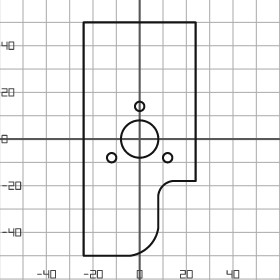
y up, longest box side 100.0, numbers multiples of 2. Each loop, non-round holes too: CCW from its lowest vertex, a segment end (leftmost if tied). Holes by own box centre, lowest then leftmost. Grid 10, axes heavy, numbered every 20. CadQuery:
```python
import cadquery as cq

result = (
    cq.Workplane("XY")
    .moveTo(-24.0, -50.0)
    .lineTo(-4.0, -50.0)
    .threePointArc((4.0, -46.0), (8.0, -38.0))
    .lineTo(8.0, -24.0)
    .threePointArc((10.0, -20.0), (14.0, -18.0))
    .lineTo(24.0, -18.0)
    .lineTo(24.0, 50.0)
    .lineTo(-24.0, 50.0)
    .close()
    .moveTo(-12.0, -8.0)
    .circle(2.0)
    .moveTo(12.0, -8.0)
    .circle(2.0)
    .moveTo(0.0, 0.0)
    .circle(8.0)
    .moveTo(0.0, 14.0)
    .circle(2.0)
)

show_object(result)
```